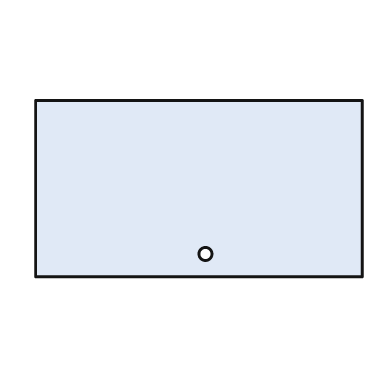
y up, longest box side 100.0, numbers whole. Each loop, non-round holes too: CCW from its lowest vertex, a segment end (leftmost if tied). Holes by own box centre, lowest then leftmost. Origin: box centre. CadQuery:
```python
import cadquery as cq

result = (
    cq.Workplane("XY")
    .moveTo(-50.0, -27.0)
    .lineTo(50.0, -27.0)
    .lineTo(50.0, 27.0)
    .lineTo(-50.0, 27.0)
    .close()
    .moveTo(2.0, -20.0)
    .circle(2.0)
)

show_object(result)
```